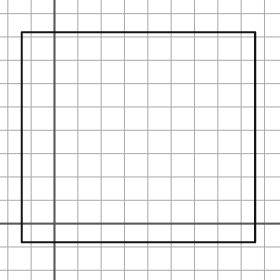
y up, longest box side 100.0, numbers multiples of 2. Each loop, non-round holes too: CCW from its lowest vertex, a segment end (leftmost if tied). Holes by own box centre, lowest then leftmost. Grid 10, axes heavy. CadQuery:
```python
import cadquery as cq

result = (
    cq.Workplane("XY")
    .moveTo(-14.0, -8.0)
    .lineTo(86.0, -8.0)
    .lineTo(86.0, 82.0)
    .lineTo(-14.0, 82.0)
    .close()
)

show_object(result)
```